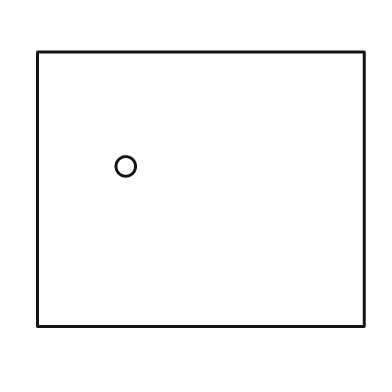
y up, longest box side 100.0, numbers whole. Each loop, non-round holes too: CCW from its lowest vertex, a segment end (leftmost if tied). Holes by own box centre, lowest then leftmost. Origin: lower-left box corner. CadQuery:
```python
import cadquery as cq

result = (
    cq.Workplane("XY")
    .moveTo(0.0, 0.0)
    .lineTo(100.0, 0.0)
    .lineTo(100.0, 84.0)
    .lineTo(0.0, 84.0)
    .close()
    .moveTo(27.0, 49.0)
    .circle(3.0)
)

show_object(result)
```